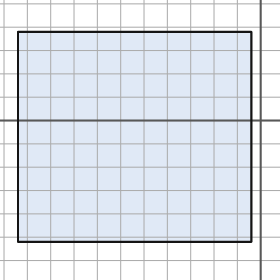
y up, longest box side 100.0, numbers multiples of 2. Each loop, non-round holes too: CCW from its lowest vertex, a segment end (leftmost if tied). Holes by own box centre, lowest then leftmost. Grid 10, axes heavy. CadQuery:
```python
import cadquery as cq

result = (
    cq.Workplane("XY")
    .moveTo(-104.0, -52.0)
    .lineTo(-4.0, -52.0)
    .lineTo(-4.0, 38.0)
    .lineTo(-104.0, 38.0)
    .close()
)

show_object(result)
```